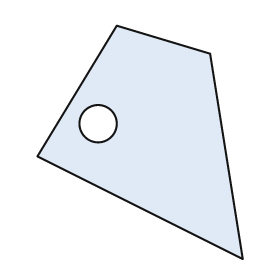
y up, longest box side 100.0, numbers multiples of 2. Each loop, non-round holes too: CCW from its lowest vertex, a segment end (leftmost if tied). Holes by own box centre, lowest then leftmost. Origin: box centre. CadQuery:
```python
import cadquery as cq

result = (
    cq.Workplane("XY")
    .moveTo(44.0, -50.0)
    .lineTo(30.0, 38.0)
    .lineTo(-10.0, 50.0)
    .lineTo(-44.0, -6.0)
    .close()
    .moveTo(-18.0, 8.0)
    .circle(8.0)
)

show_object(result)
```